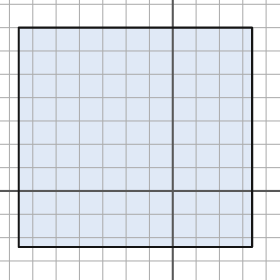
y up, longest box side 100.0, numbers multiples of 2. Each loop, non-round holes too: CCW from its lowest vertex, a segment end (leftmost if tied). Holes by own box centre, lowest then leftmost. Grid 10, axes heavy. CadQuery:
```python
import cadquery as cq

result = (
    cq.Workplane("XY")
    .moveTo(-66.0, -24.0)
    .lineTo(34.0, -24.0)
    .lineTo(34.0, 70.0)
    .lineTo(-66.0, 70.0)
    .close()
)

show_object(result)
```